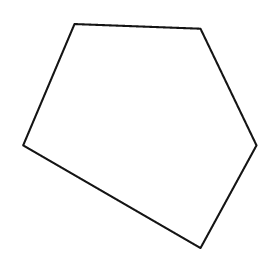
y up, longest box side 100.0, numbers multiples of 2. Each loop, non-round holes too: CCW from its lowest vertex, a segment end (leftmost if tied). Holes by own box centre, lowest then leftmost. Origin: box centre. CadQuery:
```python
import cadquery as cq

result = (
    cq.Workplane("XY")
    .moveTo(26.0, -48.0)
    .lineTo(50.0, -4.0)
    .lineTo(26.0, 46.0)
    .lineTo(-28.0, 48.0)
    .lineTo(-50.0, -4.0)
    .close()
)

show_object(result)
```